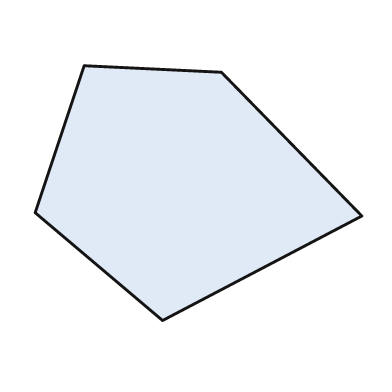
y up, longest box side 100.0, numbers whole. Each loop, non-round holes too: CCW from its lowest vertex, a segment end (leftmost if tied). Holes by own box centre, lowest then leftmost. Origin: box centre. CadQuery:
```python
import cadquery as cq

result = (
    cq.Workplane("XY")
    .moveTo(-11.0, -39.0)
    .lineTo(50.0, -7.0)
    .lineTo(7.0, 37.0)
    .lineTo(-35.0, 39.0)
    .lineTo(-50.0, -6.0)
    .close()
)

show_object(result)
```